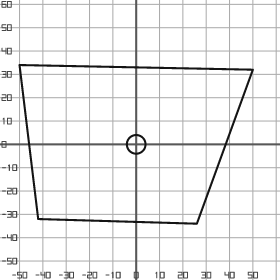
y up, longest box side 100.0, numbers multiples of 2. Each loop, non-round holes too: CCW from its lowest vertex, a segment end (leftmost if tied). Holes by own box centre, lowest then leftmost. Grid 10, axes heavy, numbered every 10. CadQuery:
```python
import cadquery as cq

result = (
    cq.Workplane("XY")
    .moveTo(26.0, -34.0)
    .lineTo(50.0, 32.0)
    .lineTo(-50.0, 34.0)
    .lineTo(-42.0, -32.0)
    .close()
    .moveTo(0.0, 0.0)
    .circle(4.0)
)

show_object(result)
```